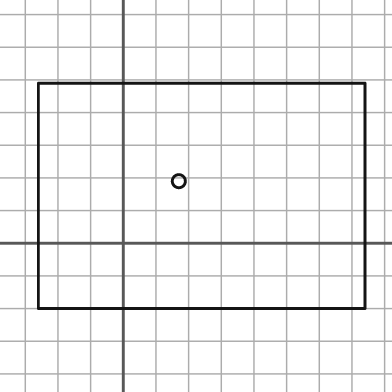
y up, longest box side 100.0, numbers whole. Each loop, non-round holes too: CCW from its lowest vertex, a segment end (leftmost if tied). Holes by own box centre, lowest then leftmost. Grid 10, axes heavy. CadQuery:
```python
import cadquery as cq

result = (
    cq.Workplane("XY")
    .moveTo(-26.0, -20.0)
    .lineTo(74.0, -20.0)
    .lineTo(74.0, 49.0)
    .lineTo(-26.0, 49.0)
    .close()
    .moveTo(17.0, 19.0)
    .circle(2.0)
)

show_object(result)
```